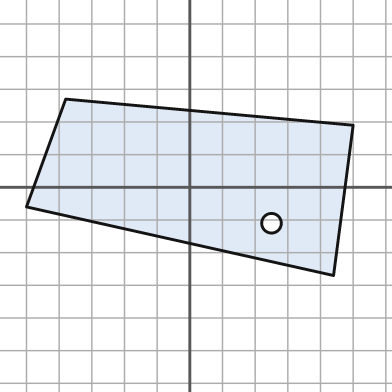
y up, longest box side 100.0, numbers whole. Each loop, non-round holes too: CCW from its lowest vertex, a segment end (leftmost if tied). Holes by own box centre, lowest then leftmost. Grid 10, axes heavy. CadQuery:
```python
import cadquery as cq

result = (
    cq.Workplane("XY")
    .moveTo(44.0, -27.0)
    .lineTo(50.0, 19.0)
    .lineTo(-38.0, 27.0)
    .lineTo(-50.0, -6.0)
    .close()
    .moveTo(25.0, -11.0)
    .circle(3.0)
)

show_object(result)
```